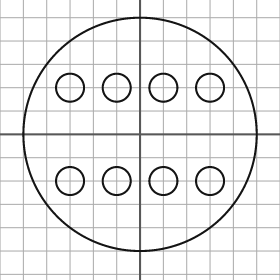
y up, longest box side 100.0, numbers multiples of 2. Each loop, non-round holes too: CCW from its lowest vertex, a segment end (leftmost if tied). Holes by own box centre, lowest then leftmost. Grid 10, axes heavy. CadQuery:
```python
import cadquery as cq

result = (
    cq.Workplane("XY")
    .moveTo(0.0, 0.0)
    .circle(50.0)
    .moveTo(-30.0, -20.0)
    .circle(6.0)
    .moveTo(-10.0, -20.0)
    .circle(6.0)
    .moveTo(10.0, -20.0)
    .circle(6.0)
    .moveTo(30.0, -20.0)
    .circle(6.0)
    .moveTo(-30.0, 20.0)
    .circle(6.0)
    .moveTo(-10.0, 20.0)
    .circle(6.0)
    .moveTo(10.0, 20.0)
    .circle(6.0)
    .moveTo(30.0, 20.0)
    .circle(6.0)
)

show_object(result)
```